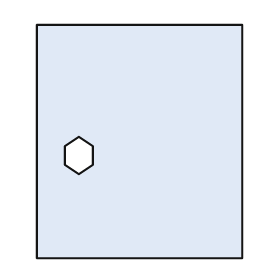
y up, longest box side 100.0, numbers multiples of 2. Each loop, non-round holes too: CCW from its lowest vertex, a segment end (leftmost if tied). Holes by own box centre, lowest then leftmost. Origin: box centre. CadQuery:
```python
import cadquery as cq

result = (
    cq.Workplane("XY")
    .moveTo(-44.0, -50.0)
    .lineTo(44.0, -50.0)
    .lineTo(44.0, 50.0)
    .lineTo(-44.0, 50.0)
    .close()
    .moveTo(-26.0, -14.0)
    .lineTo(-20.0, -10.0)
    .lineTo(-20.0, -2.0)
    .lineTo(-26.0, 2.0)
    .lineTo(-32.0, -2.0)
    .lineTo(-32.0, -10.0)
    .close()
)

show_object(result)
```